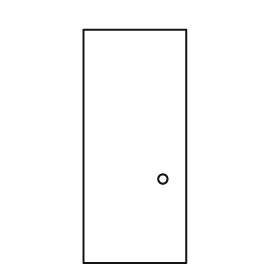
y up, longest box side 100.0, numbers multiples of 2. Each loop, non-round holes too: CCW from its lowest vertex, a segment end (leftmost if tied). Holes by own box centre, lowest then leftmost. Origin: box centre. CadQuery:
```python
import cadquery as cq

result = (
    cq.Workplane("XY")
    .moveTo(-22.0, -50.0)
    .lineTo(22.0, -50.0)
    .lineTo(22.0, 50.0)
    .lineTo(-22.0, 50.0)
    .close()
    .moveTo(12.0, -14.0)
    .circle(2.0)
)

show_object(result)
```